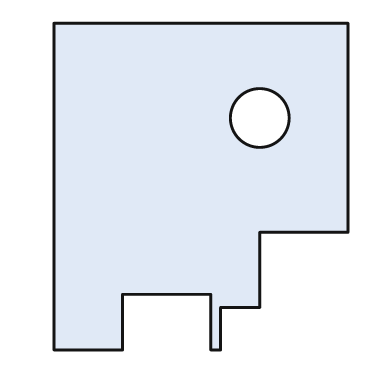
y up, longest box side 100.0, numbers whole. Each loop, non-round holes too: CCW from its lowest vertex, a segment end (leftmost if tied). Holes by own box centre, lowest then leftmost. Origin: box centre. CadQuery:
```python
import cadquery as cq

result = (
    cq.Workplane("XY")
    .moveTo(-45.0, -50.0)
    .lineTo(-24.0, -50.0)
    .lineTo(-24.0, -33.0)
    .lineTo(3.0, -33.0)
    .lineTo(3.0, -50.0)
    .lineTo(6.0, -50.0)
    .lineTo(6.0, -37.0)
    .lineTo(18.0, -37.0)
    .lineTo(18.0, -14.0)
    .lineTo(45.0, -14.0)
    .lineTo(45.0, 50.0)
    .lineTo(-45.0, 50.0)
    .close()
    .moveTo(18.0, 21.0)
    .circle(9.0)
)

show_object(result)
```